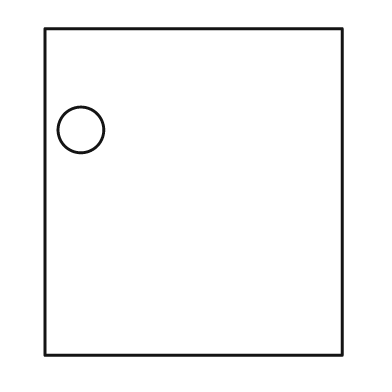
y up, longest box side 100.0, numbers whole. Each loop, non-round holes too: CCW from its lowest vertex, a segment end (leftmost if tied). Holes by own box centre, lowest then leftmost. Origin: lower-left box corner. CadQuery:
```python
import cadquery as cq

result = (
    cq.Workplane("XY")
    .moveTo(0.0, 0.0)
    .lineTo(91.0, 0.0)
    .lineTo(91.0, 100.0)
    .lineTo(0.0, 100.0)
    .close()
    .moveTo(11.0, 69.0)
    .circle(7.0)
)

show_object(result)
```